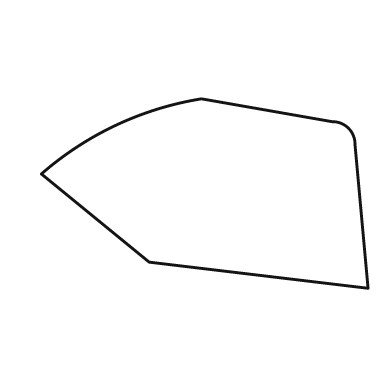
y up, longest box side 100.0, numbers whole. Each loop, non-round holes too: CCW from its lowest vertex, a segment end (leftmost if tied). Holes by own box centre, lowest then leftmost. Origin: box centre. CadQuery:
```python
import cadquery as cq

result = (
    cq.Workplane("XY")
    .moveTo(50.0, -29.0)
    .lineTo(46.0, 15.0)
    .threePointArc((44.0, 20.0), (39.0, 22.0))
    .lineTo(-1.0, 29.0)
    .threePointArc((-27.0, 21.0), (-50.0, 6.0))
    .lineTo(-17.0, -21.0)
    .close()
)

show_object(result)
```